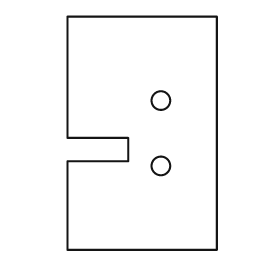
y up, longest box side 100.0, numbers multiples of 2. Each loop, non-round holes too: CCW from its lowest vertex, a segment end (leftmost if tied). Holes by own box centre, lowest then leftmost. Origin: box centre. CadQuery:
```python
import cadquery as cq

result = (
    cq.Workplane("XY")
    .moveTo(-32.0, -50.0)
    .lineTo(32.0, -50.0)
    .lineTo(32.0, 50.0)
    .lineTo(-32.0, 50.0)
    .lineTo(-32.0, -2.0)
    .lineTo(-6.0, -2.0)
    .lineTo(-6.0, -12.0)
    .lineTo(-32.0, -12.0)
    .close()
    .moveTo(8.0, -14.0)
    .circle(4.0)
    .moveTo(8.0, 14.0)
    .circle(4.0)
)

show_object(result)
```